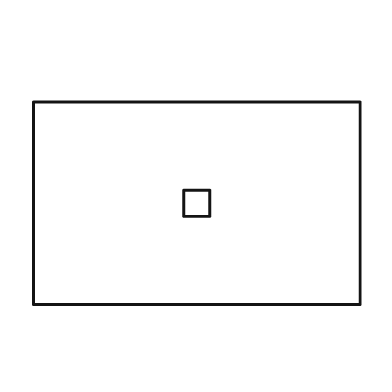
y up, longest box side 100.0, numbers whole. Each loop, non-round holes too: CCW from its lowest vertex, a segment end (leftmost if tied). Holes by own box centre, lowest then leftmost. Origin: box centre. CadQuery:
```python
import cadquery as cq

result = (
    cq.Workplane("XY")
    .moveTo(-50.0, -31.0)
    .lineTo(50.0, -31.0)
    .lineTo(50.0, 31.0)
    .lineTo(-50.0, 31.0)
    .close()
    .moveTo(-4.0, -4.0)
    .lineTo(4.0, -4.0)
    .lineTo(4.0, 4.0)
    .lineTo(-4.0, 4.0)
    .close()
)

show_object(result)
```